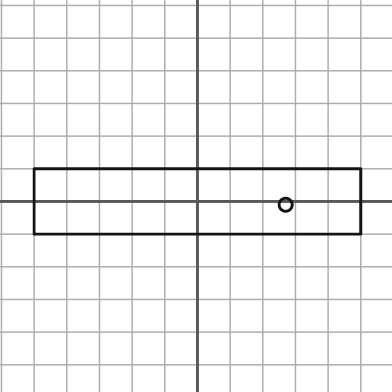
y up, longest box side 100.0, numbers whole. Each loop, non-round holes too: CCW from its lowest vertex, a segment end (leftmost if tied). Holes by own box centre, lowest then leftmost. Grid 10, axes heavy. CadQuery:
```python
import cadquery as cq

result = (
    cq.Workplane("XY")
    .moveTo(-50.0, -10.0)
    .lineTo(50.0, -10.0)
    .lineTo(50.0, 10.0)
    .lineTo(-50.0, 10.0)
    .close()
    .moveTo(27.0, -1.0)
    .circle(2.0)
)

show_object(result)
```